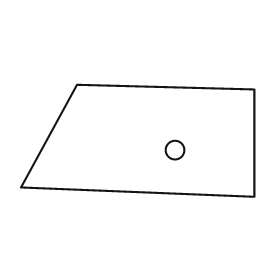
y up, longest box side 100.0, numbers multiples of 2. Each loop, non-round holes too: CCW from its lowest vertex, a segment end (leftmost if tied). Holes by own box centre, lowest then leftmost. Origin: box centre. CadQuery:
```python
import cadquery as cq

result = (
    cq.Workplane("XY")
    .moveTo(50.0, -24.0)
    .lineTo(50.0, 22.0)
    .lineTo(-26.0, 24.0)
    .lineTo(-50.0, -20.0)
    .close()
    .moveTo(16.0, -4.0)
    .circle(4.0)
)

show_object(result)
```